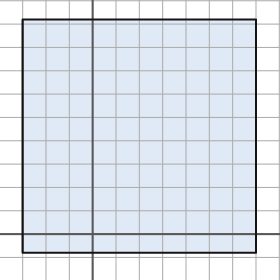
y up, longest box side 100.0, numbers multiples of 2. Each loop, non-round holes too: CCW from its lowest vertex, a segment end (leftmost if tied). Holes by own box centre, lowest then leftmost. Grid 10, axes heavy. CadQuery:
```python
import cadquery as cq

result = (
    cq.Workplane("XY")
    .moveTo(-30.0, -8.0)
    .lineTo(70.0, -8.0)
    .lineTo(70.0, 92.0)
    .lineTo(-30.0, 92.0)
    .close()
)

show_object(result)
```